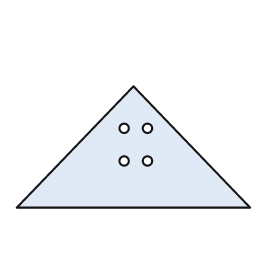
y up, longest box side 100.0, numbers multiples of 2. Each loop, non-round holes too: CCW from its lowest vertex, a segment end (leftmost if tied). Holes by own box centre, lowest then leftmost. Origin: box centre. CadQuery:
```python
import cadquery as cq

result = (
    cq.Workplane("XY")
    .moveTo(-50.0, -26.0)
    .lineTo(50.0, -26.0)
    .lineTo(0.0, 26.0)
    .close()
    .moveTo(-4.0, -6.0)
    .circle(2.0)
    .moveTo(6.0, -6.0)
    .circle(2.0)
    .moveTo(-4.0, 8.0)
    .circle(2.0)
    .moveTo(6.0, 8.0)
    .circle(2.0)
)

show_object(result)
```